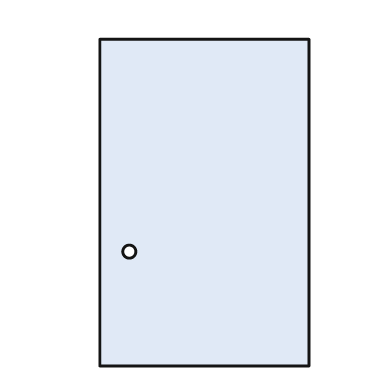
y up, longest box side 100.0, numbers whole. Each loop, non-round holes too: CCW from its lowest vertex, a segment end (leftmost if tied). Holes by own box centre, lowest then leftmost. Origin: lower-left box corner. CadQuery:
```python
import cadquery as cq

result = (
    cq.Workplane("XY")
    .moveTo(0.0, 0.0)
    .lineTo(64.0, 0.0)
    .lineTo(64.0, 100.0)
    .lineTo(0.0, 100.0)
    .close()
    .moveTo(9.0, 35.0)
    .circle(2.0)
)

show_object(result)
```